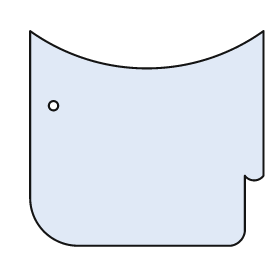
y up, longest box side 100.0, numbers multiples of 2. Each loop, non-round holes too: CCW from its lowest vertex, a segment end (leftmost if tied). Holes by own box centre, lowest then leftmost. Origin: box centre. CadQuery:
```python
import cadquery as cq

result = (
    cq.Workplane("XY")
    .moveTo(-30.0, -46.0)
    .lineTo(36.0, -46.0)
    .threePointArc((40.0, -44.0), (42.0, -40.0))
    .lineTo(42.0, -16.0)
    .threePointArc((46.0, -18.0), (50.0, -16.0))
    .lineTo(50.0, 46.0)
    .threePointArc((0.0, 30.0), (-50.0, 46.0))
    .lineTo(-50.0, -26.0)
    .threePointArc((-44.0, -40.0), (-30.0, -46.0))
    .close()
    .moveTo(-40.0, 14.0)
    .circle(2.0)
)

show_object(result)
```